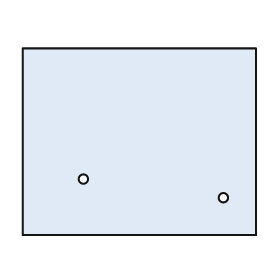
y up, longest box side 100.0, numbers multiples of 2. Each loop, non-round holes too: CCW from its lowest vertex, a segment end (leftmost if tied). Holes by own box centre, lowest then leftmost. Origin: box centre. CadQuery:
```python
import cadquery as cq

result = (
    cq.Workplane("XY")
    .moveTo(-50.0, -40.0)
    .lineTo(50.0, -40.0)
    .lineTo(50.0, 40.0)
    .lineTo(-50.0, 40.0)
    .close()
    .moveTo(36.0, -24.0)
    .circle(2.0)
    .moveTo(-24.0, -16.0)
    .circle(2.0)
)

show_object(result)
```